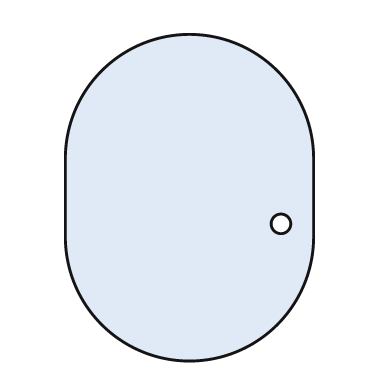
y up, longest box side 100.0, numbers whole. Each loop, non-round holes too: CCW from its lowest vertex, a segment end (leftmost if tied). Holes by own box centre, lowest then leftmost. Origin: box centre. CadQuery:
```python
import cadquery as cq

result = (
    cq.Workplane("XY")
    .moveTo(-38.0, -12.0)
    .threePointArc((0.0, -50.0), (38.0, -12.0))
    .lineTo(38.0, 12.0)
    .threePointArc((0.0, 50.0), (-38.0, 12.0))
    .close()
    .moveTo(28.0, -8.0)
    .circle(3.0)
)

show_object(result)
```